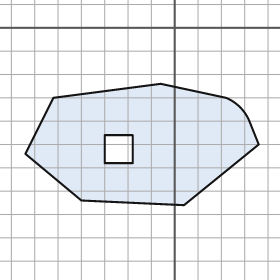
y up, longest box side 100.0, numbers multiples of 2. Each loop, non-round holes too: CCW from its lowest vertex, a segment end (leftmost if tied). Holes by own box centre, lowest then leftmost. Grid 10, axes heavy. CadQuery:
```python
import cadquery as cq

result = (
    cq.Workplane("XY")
    .moveTo(4.0, -76.0)
    .lineTo(36.0, -50.0)
    .lineTo(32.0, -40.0)
    .threePointArc((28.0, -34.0), (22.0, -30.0))
    .lineTo(-6.0, -24.0)
    .lineTo(-52.0, -30.0)
    .lineTo(-64.0, -54.0)
    .lineTo(-40.0, -74.0)
    .close()
    .moveTo(-30.0, -58.0)
    .lineTo(-18.0, -58.0)
    .lineTo(-18.0, -46.0)
    .lineTo(-30.0, -46.0)
    .close()
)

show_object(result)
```